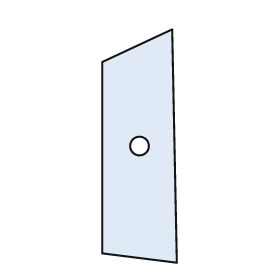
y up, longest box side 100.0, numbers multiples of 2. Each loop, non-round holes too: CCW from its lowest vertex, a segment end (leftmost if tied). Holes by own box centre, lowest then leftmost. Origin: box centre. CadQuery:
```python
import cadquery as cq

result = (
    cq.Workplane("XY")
    .moveTo(16.0, -50.0)
    .lineTo(14.0, 50.0)
    .lineTo(-16.0, 36.0)
    .lineTo(-16.0, -46.0)
    .close()
    .moveTo(0.0, 0.0)
    .circle(4.0)
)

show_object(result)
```